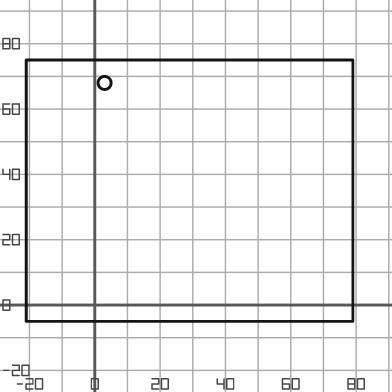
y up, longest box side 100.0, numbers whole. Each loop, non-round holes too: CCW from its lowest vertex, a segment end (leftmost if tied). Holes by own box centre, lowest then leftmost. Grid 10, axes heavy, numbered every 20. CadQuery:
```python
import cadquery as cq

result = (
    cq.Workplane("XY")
    .moveTo(-21.0, -5.0)
    .lineTo(79.0, -5.0)
    .lineTo(79.0, 75.0)
    .lineTo(-21.0, 75.0)
    .close()
    .moveTo(3.0, 68.0)
    .circle(2.0)
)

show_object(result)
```